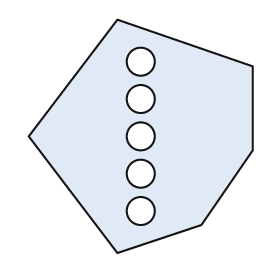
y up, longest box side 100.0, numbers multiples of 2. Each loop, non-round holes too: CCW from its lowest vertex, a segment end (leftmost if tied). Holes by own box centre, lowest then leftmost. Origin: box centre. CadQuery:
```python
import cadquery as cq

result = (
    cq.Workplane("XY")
    .moveTo(-10.0, -50.0)
    .lineTo(26.0, -38.0)
    .lineTo(48.0, -6.0)
    .lineTo(48.0, 30.0)
    .lineTo(-10.0, 50.0)
    .lineTo(-48.0, 0.0)
    .close()
    .moveTo(0.0, -32.0)
    .circle(6.0)
    .moveTo(0.0, -16.0)
    .circle(6.0)
    .moveTo(0.0, 0.0)
    .circle(6.0)
    .moveTo(0.0, 16.0)
    .circle(6.0)
    .moveTo(0.0, 32.0)
    .circle(6.0)
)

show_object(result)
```